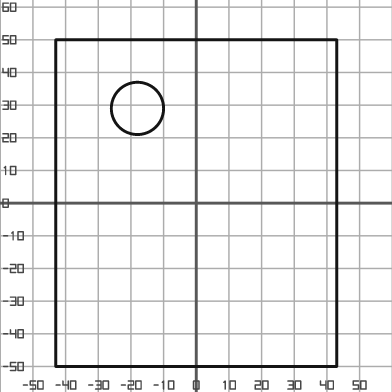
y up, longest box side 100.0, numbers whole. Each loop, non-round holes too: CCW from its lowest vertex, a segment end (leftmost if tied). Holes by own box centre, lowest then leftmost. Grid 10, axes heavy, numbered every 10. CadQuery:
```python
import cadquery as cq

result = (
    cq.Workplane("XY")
    .moveTo(-43.0, -50.0)
    .lineTo(43.0, -50.0)
    .lineTo(43.0, 50.0)
    .lineTo(-43.0, 50.0)
    .close()
    .moveTo(-18.0, 29.0)
    .circle(8.0)
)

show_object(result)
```